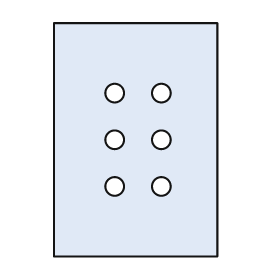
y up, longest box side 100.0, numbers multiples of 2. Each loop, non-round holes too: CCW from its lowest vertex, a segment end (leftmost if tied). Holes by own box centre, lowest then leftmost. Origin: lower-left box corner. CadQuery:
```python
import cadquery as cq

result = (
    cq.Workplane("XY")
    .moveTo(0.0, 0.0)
    .lineTo(70.0, 0.0)
    .lineTo(70.0, 100.0)
    .lineTo(0.0, 100.0)
    .close()
    .moveTo(26.0, 30.0)
    .circle(4.0)
    .moveTo(46.0, 30.0)
    .circle(4.0)
    .moveTo(26.0, 50.0)
    .circle(4.0)
    .moveTo(46.0, 50.0)
    .circle(4.0)
    .moveTo(26.0, 70.0)
    .circle(4.0)
    .moveTo(46.0, 70.0)
    .circle(4.0)
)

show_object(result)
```